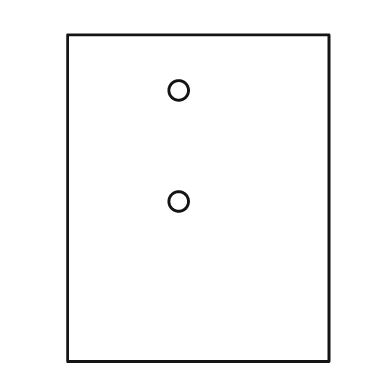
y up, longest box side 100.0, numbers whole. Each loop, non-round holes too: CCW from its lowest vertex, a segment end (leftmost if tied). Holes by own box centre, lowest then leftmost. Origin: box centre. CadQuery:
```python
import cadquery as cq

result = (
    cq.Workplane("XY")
    .moveTo(-40.0, -50.0)
    .lineTo(40.0, -50.0)
    .lineTo(40.0, 50.0)
    .lineTo(-40.0, 50.0)
    .close()
    .moveTo(-6.0, -1.0)
    .circle(3.0)
    .moveTo(-6.0, 33.0)
    .circle(3.0)
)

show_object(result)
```